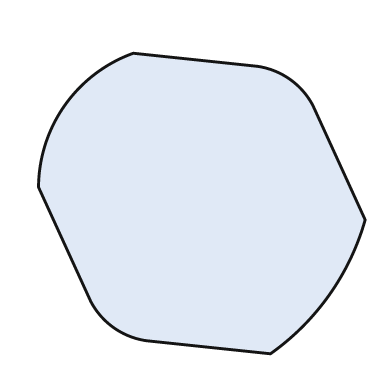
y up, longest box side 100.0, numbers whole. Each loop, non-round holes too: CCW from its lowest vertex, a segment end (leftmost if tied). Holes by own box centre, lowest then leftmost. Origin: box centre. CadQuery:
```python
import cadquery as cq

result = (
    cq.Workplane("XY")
    .moveTo(21.0, -46.0)
    .threePointArc((39.0, -28.0), (50.0, -5.0))
    .lineTo(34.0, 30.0)
    .threePointArc((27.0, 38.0), (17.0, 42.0))
    .lineTo(-21.0, 46.0)
    .threePointArc((-42.0, 30.0), (-50.0, 5.0))
    .lineTo(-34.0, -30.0)
    .threePointArc((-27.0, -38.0), (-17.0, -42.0))
    .close()
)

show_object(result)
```